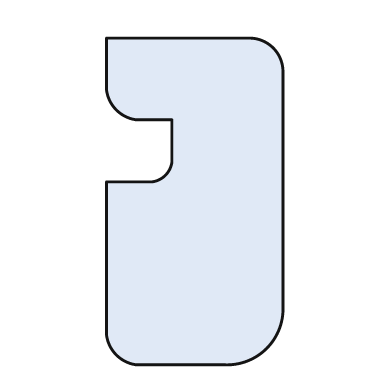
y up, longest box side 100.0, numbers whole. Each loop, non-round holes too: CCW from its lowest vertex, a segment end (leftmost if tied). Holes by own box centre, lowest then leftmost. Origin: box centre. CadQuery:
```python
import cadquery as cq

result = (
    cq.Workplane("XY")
    .moveTo(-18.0, -50.0)
    .lineTo(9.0, -50.0)
    .threePointArc((22.0, -45.0), (27.0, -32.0))
    .lineTo(27.0, 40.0)
    .threePointArc((24.0, 47.0), (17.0, 50.0))
    .lineTo(-27.0, 50.0)
    .lineTo(-27.0, 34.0)
    .threePointArc((-24.0, 28.0), (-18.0, 25.0))
    .lineTo(-7.0, 25.0)
    .lineTo(-7.0, 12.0)
    .threePointArc((-9.0, 8.0), (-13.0, 6.0))
    .lineTo(-27.0, 6.0)
    .lineTo(-27.0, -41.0)
    .threePointArc((-24.0, -47.0), (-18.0, -50.0))
    .close()
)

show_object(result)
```